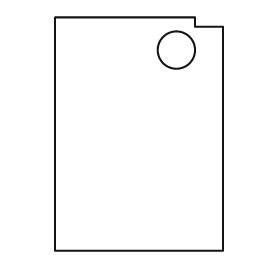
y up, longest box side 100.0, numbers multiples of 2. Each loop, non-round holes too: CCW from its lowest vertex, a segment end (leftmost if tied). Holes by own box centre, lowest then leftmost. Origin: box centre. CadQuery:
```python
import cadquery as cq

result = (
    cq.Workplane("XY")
    .moveTo(-36.0, -50.0)
    .lineTo(36.0, -50.0)
    .lineTo(36.0, 46.0)
    .lineTo(24.0, 46.0)
    .lineTo(24.0, 50.0)
    .lineTo(-36.0, 50.0)
    .close()
    .moveTo(16.0, 36.0)
    .circle(8.0)
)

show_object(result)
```